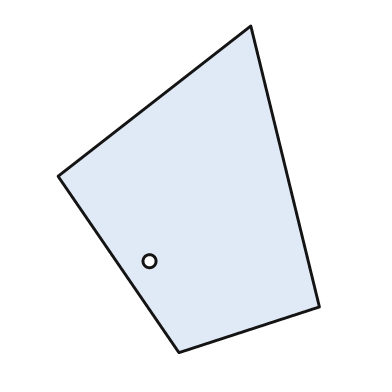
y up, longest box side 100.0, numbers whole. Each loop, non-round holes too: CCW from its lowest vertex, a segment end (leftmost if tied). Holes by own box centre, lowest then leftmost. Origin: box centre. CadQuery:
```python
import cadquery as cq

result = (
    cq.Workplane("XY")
    .moveTo(-3.0, -50.0)
    .lineTo(40.0, -36.0)
    .lineTo(19.0, 50.0)
    .lineTo(-40.0, 4.0)
    .close()
    .moveTo(-12.0, -22.0)
    .circle(2.0)
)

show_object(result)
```